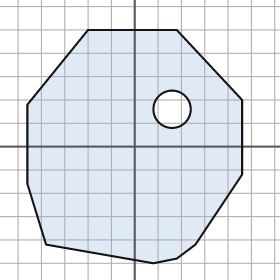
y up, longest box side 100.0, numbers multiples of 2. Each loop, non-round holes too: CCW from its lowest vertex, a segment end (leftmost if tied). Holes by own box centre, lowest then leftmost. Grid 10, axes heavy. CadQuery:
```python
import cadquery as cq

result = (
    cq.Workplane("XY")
    .moveTo(8.0, -50.0)
    .lineTo(18.0, -48.0)
    .lineTo(26.0, -42.0)
    .lineTo(46.0, -12.0)
    .lineTo(46.0, 20.0)
    .lineTo(18.0, 50.0)
    .lineTo(-20.0, 50.0)
    .lineTo(-46.0, 18.0)
    .lineTo(-46.0, -16.0)
    .lineTo(-38.0, -42.0)
    .close()
    .moveTo(16.0, 16.0)
    .circle(8.0)
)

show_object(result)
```